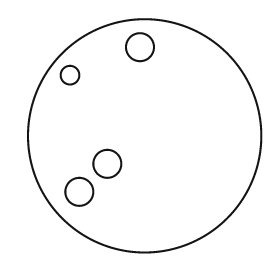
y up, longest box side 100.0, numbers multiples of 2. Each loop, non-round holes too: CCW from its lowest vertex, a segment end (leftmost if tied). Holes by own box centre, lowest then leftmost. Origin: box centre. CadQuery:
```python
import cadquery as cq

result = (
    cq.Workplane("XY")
    .moveTo(0.0, 0.0)
    .circle(50.0)
    .moveTo(-28.0, -24.0)
    .circle(6.0)
    .moveTo(-16.0, -12.0)
    .circle(6.0)
    .moveTo(-32.0, 26.0)
    .circle(4.0)
    .moveTo(-2.0, 38.0)
    .circle(6.0)
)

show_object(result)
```